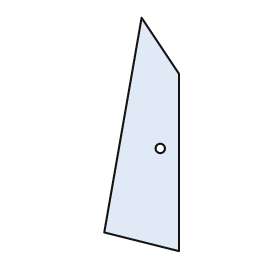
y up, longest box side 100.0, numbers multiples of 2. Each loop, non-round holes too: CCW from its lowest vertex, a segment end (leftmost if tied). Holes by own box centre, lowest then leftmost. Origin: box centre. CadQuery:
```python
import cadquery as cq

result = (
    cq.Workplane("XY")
    .moveTo(16.0, -50.0)
    .lineTo(16.0, 26.0)
    .lineTo(0.0, 50.0)
    .lineTo(-16.0, -42.0)
    .close()
    .moveTo(8.0, -6.0)
    .circle(2.0)
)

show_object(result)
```